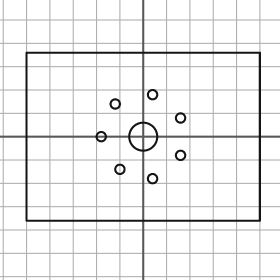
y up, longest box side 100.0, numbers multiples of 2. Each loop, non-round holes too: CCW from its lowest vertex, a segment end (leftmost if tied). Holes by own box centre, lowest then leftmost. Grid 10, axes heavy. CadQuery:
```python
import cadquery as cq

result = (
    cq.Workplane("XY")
    .moveTo(-50.0, -36.0)
    .lineTo(50.0, -36.0)
    .lineTo(50.0, 36.0)
    .lineTo(-50.0, 36.0)
    .close()
    .moveTo(4.0, -18.0)
    .circle(2.0)
    .moveTo(-10.0, -14.0)
    .circle(2.0)
    .moveTo(16.0, -8.0)
    .circle(2.0)
    .moveTo(-18.0, 0.0)
    .circle(2.0)
    .moveTo(0.0, 0.0)
    .circle(6.0)
    .moveTo(16.0, 8.0)
    .circle(2.0)
    .moveTo(-12.0, 14.0)
    .circle(2.0)
    .moveTo(4.0, 18.0)
    .circle(2.0)
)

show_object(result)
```